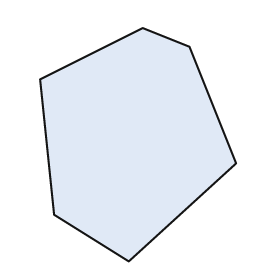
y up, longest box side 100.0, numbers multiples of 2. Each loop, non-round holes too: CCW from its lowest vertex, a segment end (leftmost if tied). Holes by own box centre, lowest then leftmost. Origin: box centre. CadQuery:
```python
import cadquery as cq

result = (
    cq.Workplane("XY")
    .moveTo(-4.0, -50.0)
    .lineTo(42.0, -8.0)
    .lineTo(22.0, 42.0)
    .lineTo(2.0, 50.0)
    .lineTo(-42.0, 28.0)
    .lineTo(-36.0, -30.0)
    .close()
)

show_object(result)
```